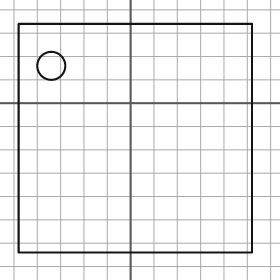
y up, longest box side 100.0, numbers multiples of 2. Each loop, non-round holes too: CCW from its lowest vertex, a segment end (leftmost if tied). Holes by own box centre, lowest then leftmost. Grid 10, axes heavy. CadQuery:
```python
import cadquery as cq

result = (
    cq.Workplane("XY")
    .moveTo(-48.0, -64.0)
    .lineTo(52.0, -64.0)
    .lineTo(52.0, 34.0)
    .lineTo(-48.0, 34.0)
    .close()
    .moveTo(-34.0, 16.0)
    .circle(6.0)
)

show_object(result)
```